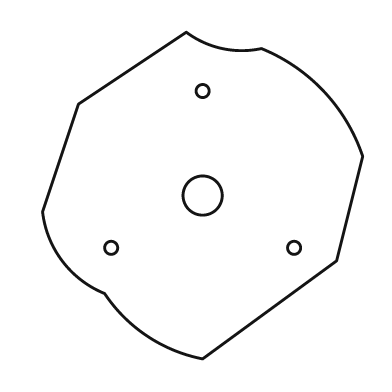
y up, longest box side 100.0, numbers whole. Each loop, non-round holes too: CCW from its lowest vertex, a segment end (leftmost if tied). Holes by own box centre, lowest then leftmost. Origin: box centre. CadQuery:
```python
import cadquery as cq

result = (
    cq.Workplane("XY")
    .moveTo(0.0, -50.0)
    .lineTo(41.0, -20.0)
    .lineTo(49.0, 12.0)
    .threePointArc((37.0, 32.0), (18.0, 45.0))
    .threePointArc((6.0, 45.0), (-5.0, 50.0))
    .lineTo(-38.0, 28.0)
    .lineTo(-49.0, -5.0)
    .threePointArc((-43.0, -20.0), (-30.0, -30.0))
    .threePointArc((-17.0, -43.0), (0.0, -50.0))
    .close()
    .moveTo(-28.0, -16.0)
    .circle(2.0)
    .moveTo(28.0, -16.0)
    .circle(2.0)
    .moveTo(0.0, 0.0)
    .circle(6.0)
    .moveTo(0.0, 32.0)
    .circle(2.0)
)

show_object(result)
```